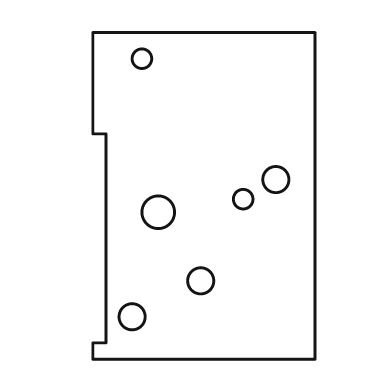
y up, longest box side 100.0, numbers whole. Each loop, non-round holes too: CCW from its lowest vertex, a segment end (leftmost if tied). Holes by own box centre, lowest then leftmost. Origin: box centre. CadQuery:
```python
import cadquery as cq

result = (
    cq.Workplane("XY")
    .moveTo(-34.0, -50.0)
    .lineTo(34.0, -50.0)
    .lineTo(34.0, 50.0)
    .lineTo(-34.0, 50.0)
    .lineTo(-34.0, 19.0)
    .lineTo(-30.0, 19.0)
    .lineTo(-30.0, -45.0)
    .lineTo(-34.0, -45.0)
    .close()
    .moveTo(-22.0, -37.0)
    .circle(4.0)
    .moveTo(-1.0, -26.0)
    .circle(4.0)
    .moveTo(-14.0, -5.0)
    .circle(5.0)
    .moveTo(12.0, -1.0)
    .circle(3.0)
    .moveTo(22.0, 5.0)
    .circle(4.0)
    .moveTo(-19.0, 42.0)
    .circle(3.0)
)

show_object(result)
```